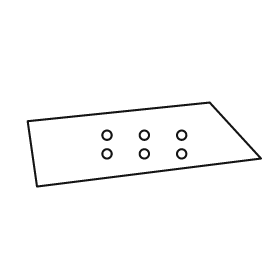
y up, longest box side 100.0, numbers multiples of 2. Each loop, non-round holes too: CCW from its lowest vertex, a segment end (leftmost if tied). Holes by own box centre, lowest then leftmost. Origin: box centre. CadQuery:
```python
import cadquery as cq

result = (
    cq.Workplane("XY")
    .moveTo(-46.0, -18.0)
    .lineTo(50.0, -6.0)
    .lineTo(28.0, 18.0)
    .lineTo(-50.0, 10.0)
    .close()
    .moveTo(-16.0, -4.0)
    .circle(2.0)
    .moveTo(0.0, -4.0)
    .circle(2.0)
    .moveTo(16.0, -4.0)
    .circle(2.0)
    .moveTo(-16.0, 4.0)
    .circle(2.0)
    .moveTo(0.0, 4.0)
    .circle(2.0)
    .moveTo(16.0, 4.0)
    .circle(2.0)
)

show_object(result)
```